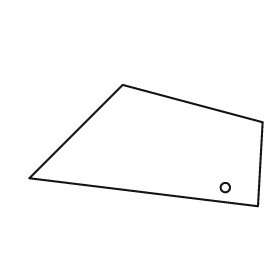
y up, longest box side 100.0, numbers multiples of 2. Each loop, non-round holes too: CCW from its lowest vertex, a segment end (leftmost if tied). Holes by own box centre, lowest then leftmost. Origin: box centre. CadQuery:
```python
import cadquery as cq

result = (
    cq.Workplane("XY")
    .moveTo(48.0, -26.0)
    .lineTo(50.0, 10.0)
    .lineTo(-10.0, 26.0)
    .lineTo(-50.0, -14.0)
    .close()
    .moveTo(34.0, -18.0)
    .circle(2.0)
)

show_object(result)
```